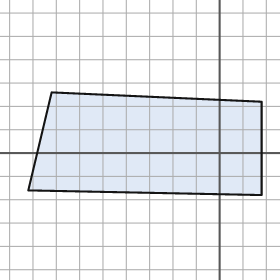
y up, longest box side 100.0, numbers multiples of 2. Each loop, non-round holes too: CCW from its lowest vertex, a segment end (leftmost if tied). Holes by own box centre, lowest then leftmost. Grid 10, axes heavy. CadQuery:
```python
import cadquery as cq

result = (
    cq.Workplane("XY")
    .moveTo(18.0, -18.0)
    .lineTo(18.0, 22.0)
    .lineTo(-72.0, 26.0)
    .lineTo(-82.0, -16.0)
    .close()
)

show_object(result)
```